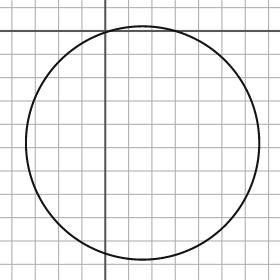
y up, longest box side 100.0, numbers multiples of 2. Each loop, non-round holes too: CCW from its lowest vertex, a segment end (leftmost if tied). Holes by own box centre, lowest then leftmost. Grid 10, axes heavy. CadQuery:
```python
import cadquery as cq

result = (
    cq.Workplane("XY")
    .moveTo(16.0, -48.0)
    .circle(50.0)
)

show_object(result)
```